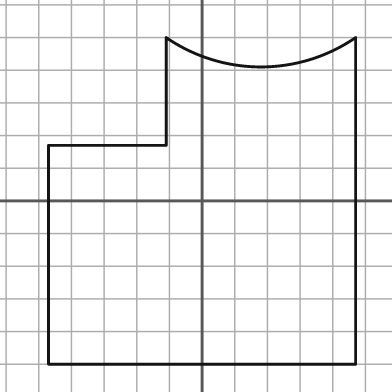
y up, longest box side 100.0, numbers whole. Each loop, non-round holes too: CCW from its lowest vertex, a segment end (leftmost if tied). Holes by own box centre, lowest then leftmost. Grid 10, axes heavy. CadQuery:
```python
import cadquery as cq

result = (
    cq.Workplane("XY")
    .moveTo(-47.0, -50.0)
    .lineTo(47.0, -50.0)
    .lineTo(47.0, 50.0)
    .threePointArc((18.0, 41.0), (-11.0, 50.0))
    .lineTo(-11.0, 17.0)
    .lineTo(-47.0, 17.0)
    .close()
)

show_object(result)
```